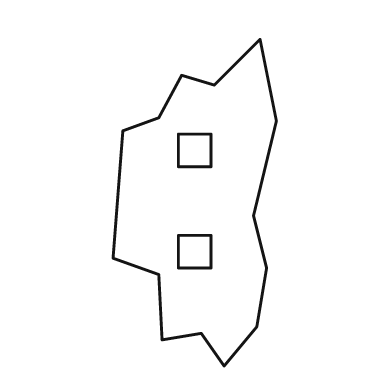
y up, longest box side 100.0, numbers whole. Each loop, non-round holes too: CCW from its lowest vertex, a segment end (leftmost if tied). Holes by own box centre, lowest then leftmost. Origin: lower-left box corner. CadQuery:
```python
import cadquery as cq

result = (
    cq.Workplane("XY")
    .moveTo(34.0, 0.0)
    .lineTo(44.0, 12.0)
    .lineTo(47.0, 30.0)
    .lineTo(43.0, 46.0)
    .lineTo(50.0, 75.0)
    .lineTo(45.0, 100.0)
    .lineTo(31.0, 86.0)
    .lineTo(21.0, 89.0)
    .lineTo(14.0, 76.0)
    .lineTo(3.0, 72.0)
    .lineTo(0.0, 33.0)
    .lineTo(14.0, 28.0)
    .lineTo(15.0, 8.0)
    .lineTo(27.0, 10.0)
    .close()
    .moveTo(20.0, 30.0)
    .lineTo(30.0, 30.0)
    .lineTo(30.0, 40.0)
    .lineTo(20.0, 40.0)
    .close()
    .moveTo(20.0, 61.0)
    .lineTo(30.0, 61.0)
    .lineTo(30.0, 71.0)
    .lineTo(20.0, 71.0)
    .close()
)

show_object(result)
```